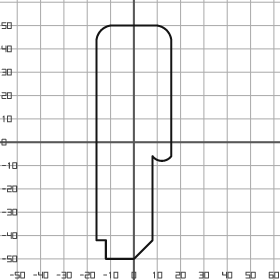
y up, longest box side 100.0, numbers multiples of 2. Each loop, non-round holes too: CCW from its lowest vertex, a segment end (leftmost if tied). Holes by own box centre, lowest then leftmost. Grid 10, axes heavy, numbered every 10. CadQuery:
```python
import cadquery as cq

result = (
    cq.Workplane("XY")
    .moveTo(-12.0, -50.0)
    .lineTo(0.0, -50.0)
    .lineTo(8.0, -42.0)
    .lineTo(8.0, -6.0)
    .threePointArc((12.0, -8.0), (16.0, -6.0))
    .lineTo(16.0, 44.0)
    .threePointArc((14.0, 48.0), (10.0, 50.0))
    .lineTo(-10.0, 50.0)
    .threePointArc((-14.0, 48.0), (-16.0, 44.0))
    .lineTo(-16.0, -42.0)
    .lineTo(-12.0, -42.0)
    .close()
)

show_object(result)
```